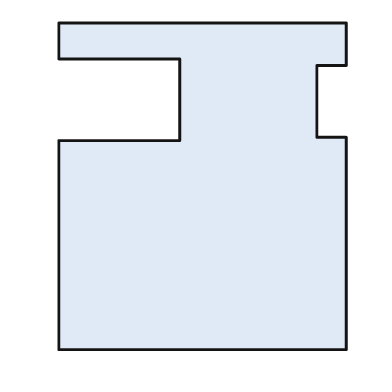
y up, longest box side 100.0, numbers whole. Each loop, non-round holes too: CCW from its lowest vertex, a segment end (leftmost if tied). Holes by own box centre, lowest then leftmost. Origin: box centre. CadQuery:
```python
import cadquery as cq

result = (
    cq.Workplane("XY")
    .moveTo(-44.0, -50.0)
    .lineTo(44.0, -50.0)
    .lineTo(44.0, 15.0)
    .lineTo(35.0, 15.0)
    .lineTo(35.0, 37.0)
    .lineTo(44.0, 37.0)
    .lineTo(44.0, 50.0)
    .lineTo(-44.0, 50.0)
    .lineTo(-44.0, 39.0)
    .lineTo(-7.0, 39.0)
    .lineTo(-7.0, 14.0)
    .lineTo(-44.0, 14.0)
    .close()
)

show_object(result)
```